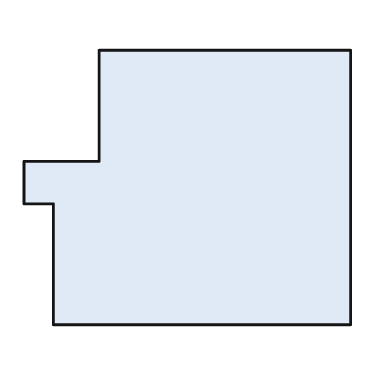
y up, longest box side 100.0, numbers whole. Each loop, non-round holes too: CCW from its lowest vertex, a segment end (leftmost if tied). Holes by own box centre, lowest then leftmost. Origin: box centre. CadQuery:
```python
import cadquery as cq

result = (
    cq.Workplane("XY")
    .moveTo(-41.0, -42.0)
    .lineTo(50.0, -42.0)
    .lineTo(50.0, 42.0)
    .lineTo(-27.0, 42.0)
    .lineTo(-27.0, 8.0)
    .lineTo(-50.0, 8.0)
    .lineTo(-50.0, -5.0)
    .lineTo(-41.0, -5.0)
    .close()
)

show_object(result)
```